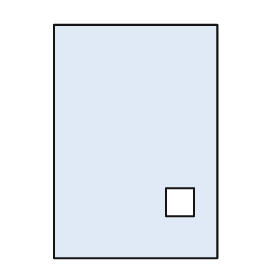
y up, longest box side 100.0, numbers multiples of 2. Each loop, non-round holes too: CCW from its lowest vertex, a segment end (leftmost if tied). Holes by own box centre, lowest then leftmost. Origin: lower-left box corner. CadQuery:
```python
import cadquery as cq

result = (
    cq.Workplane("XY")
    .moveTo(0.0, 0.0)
    .lineTo(70.0, 0.0)
    .lineTo(70.0, 100.0)
    .lineTo(0.0, 100.0)
    .close()
    .moveTo(48.0, 18.0)
    .lineTo(60.0, 18.0)
    .lineTo(60.0, 30.0)
    .lineTo(48.0, 30.0)
    .close()
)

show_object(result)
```